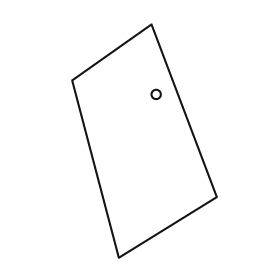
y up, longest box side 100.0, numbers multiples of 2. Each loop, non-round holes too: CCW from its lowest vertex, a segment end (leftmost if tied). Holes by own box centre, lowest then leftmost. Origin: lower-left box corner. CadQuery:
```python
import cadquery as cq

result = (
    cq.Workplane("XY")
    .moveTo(20.0, 0.0)
    .lineTo(62.0, 26.0)
    .lineTo(34.0, 100.0)
    .lineTo(0.0, 76.0)
    .close()
    .moveTo(36.0, 70.0)
    .circle(2.0)
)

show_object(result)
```